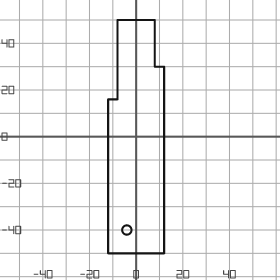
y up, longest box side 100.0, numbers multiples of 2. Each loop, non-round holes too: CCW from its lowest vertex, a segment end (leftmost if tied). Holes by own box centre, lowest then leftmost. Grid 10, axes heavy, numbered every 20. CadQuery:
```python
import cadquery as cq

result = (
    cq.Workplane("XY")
    .moveTo(-12.0, -50.0)
    .lineTo(12.0, -50.0)
    .lineTo(12.0, 30.0)
    .lineTo(8.0, 30.0)
    .lineTo(8.0, 50.0)
    .lineTo(-8.0, 50.0)
    .lineTo(-8.0, 16.0)
    .lineTo(-12.0, 16.0)
    .close()
    .moveTo(-4.0, -40.0)
    .circle(2.0)
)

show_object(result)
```